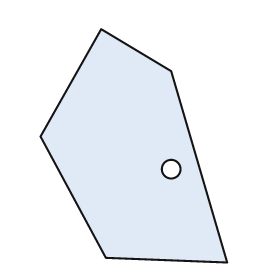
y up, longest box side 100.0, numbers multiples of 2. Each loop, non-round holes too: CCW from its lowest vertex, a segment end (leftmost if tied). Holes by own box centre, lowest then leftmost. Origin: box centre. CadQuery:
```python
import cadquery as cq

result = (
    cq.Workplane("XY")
    .moveTo(40.0, -50.0)
    .lineTo(16.0, 32.0)
    .lineTo(-14.0, 50.0)
    .lineTo(-40.0, 4.0)
    .lineTo(-12.0, -48.0)
    .close()
    .moveTo(16.0, -10.0)
    .circle(4.0)
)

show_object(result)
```